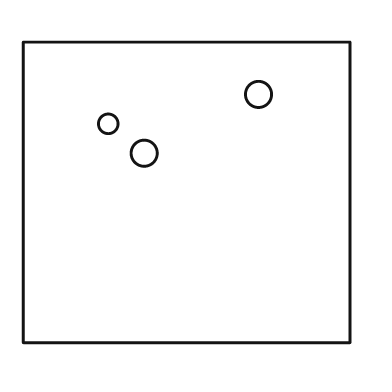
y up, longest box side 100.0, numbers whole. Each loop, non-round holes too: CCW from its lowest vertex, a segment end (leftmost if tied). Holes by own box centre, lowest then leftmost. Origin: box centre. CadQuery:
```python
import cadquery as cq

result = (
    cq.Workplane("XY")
    .moveTo(-50.0, -46.0)
    .lineTo(50.0, -46.0)
    .lineTo(50.0, 46.0)
    .lineTo(-50.0, 46.0)
    .close()
    .moveTo(-13.0, 12.0)
    .circle(4.0)
    .moveTo(-24.0, 21.0)
    .circle(3.0)
    .moveTo(22.0, 30.0)
    .circle(4.0)
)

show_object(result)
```